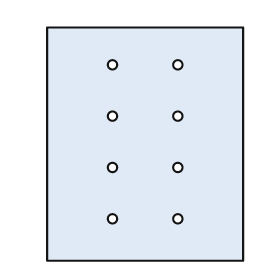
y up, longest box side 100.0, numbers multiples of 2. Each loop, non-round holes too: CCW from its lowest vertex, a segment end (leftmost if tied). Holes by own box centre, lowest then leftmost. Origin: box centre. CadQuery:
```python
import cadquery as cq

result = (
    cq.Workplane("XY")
    .moveTo(-42.0, -50.0)
    .lineTo(42.0, -50.0)
    .lineTo(42.0, 50.0)
    .lineTo(-42.0, 50.0)
    .close()
    .moveTo(-14.0, -32.0)
    .circle(2.0)
    .moveTo(14.0, -32.0)
    .circle(2.0)
    .moveTo(-14.0, -10.0)
    .circle(2.0)
    .moveTo(14.0, -10.0)
    .circle(2.0)
    .moveTo(-14.0, 12.0)
    .circle(2.0)
    .moveTo(14.0, 12.0)
    .circle(2.0)
    .moveTo(-14.0, 34.0)
    .circle(2.0)
    .moveTo(14.0, 34.0)
    .circle(2.0)
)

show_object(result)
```